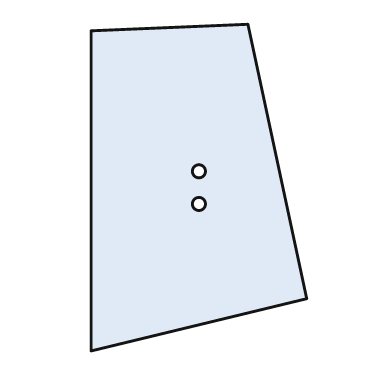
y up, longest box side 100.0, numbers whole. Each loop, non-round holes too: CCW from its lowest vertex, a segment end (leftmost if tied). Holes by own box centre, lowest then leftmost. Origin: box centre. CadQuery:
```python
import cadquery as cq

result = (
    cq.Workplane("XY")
    .moveTo(-33.0, -50.0)
    .lineTo(33.0, -34.0)
    .lineTo(15.0, 50.0)
    .lineTo(-33.0, 48.0)
    .close()
    .moveTo(0.0, -5.0)
    .circle(2.0)
    .moveTo(0.0, 5.0)
    .circle(2.0)
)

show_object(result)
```